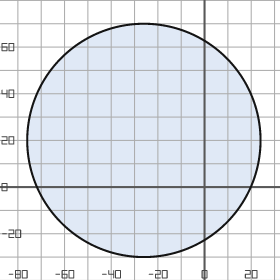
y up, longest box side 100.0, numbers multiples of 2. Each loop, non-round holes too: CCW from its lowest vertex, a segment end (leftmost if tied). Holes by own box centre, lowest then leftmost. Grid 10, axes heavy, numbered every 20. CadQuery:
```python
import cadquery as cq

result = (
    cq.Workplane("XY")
    .moveTo(-26.0, 20.0)
    .circle(50.0)
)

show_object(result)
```